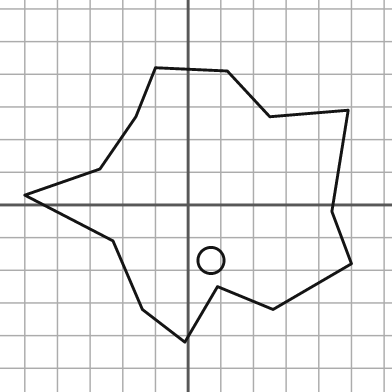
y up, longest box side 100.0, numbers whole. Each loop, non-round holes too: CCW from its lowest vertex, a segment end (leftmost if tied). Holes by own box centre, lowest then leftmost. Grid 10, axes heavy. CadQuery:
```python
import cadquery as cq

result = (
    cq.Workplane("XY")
    .moveTo(-1.0, -42.0)
    .lineTo(9.0, -25.0)
    .lineTo(26.0, -32.0)
    .lineTo(50.0, -18.0)
    .lineTo(44.0, -2.0)
    .lineTo(49.0, 29.0)
    .lineTo(25.0, 27.0)
    .lineTo(12.0, 41.0)
    .lineTo(-10.0, 42.0)
    .lineTo(-16.0, 27.0)
    .lineTo(-27.0, 11.0)
    .lineTo(-50.0, 3.0)
    .lineTo(-23.0, -11.0)
    .lineTo(-14.0, -32.0)
    .close()
    .moveTo(7.0, -17.0)
    .circle(4.0)
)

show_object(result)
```